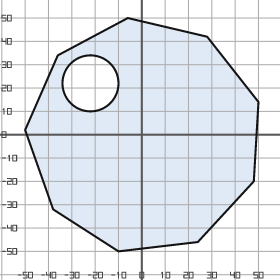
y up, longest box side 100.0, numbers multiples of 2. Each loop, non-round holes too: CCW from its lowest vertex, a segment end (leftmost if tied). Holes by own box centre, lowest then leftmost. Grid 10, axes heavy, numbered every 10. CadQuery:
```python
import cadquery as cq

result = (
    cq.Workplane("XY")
    .moveTo(-10.0, -50.0)
    .lineTo(24.0, -46.0)
    .lineTo(48.0, -20.0)
    .lineTo(50.0, 14.0)
    .lineTo(28.0, 42.0)
    .lineTo(-6.0, 50.0)
    .lineTo(-36.0, 34.0)
    .lineTo(-50.0, 2.0)
    .lineTo(-38.0, -32.0)
    .close()
    .moveTo(-22.0, 22.0)
    .circle(12.0)
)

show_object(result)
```